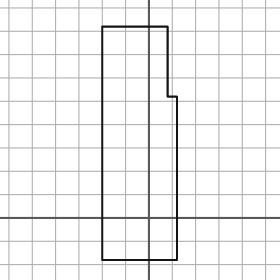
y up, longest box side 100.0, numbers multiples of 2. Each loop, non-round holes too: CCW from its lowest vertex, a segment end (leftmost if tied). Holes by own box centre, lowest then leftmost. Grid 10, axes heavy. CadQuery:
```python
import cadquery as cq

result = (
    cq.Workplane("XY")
    .moveTo(-20.0, -18.0)
    .lineTo(12.0, -18.0)
    .lineTo(12.0, 52.0)
    .lineTo(8.0, 52.0)
    .lineTo(8.0, 82.0)
    .lineTo(-20.0, 82.0)
    .close()
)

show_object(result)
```